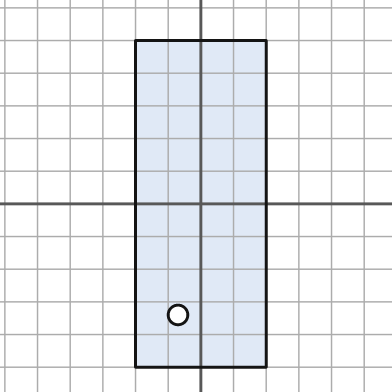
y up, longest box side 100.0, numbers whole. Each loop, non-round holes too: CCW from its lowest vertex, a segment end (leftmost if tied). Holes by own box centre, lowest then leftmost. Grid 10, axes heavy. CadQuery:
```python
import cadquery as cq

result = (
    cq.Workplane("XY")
    .moveTo(-20.0, -50.0)
    .lineTo(20.0, -50.0)
    .lineTo(20.0, 50.0)
    .lineTo(-20.0, 50.0)
    .close()
    .moveTo(-7.0, -34.0)
    .circle(3.0)
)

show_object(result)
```